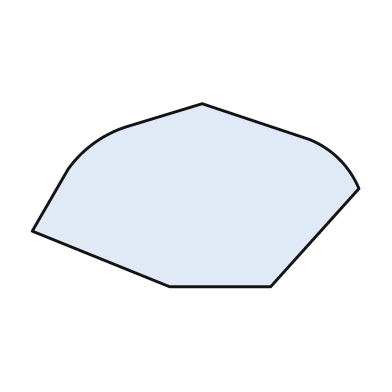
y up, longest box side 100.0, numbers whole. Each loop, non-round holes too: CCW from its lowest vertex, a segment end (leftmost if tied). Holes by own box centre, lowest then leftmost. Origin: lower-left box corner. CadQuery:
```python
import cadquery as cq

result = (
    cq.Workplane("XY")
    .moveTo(42.0, 0.0)
    .lineTo(73.0, 0.0)
    .lineTo(100.0, 30.0)
    .threePointArc((94.0, 39.0), (85.0, 45.0))
    .lineTo(52.0, 56.0)
    .lineTo(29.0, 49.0)
    .threePointArc((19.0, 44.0), (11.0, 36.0))
    .lineTo(0.0, 17.0)
    .close()
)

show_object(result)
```